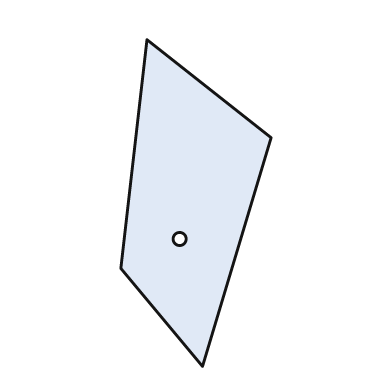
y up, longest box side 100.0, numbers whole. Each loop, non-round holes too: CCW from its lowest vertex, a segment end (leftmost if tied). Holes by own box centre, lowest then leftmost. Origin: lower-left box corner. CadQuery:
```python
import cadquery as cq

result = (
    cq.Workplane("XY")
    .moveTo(25.0, 0.0)
    .lineTo(46.0, 70.0)
    .lineTo(8.0, 100.0)
    .lineTo(0.0, 30.0)
    .close()
    .moveTo(18.0, 39.0)
    .circle(2.0)
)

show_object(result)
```